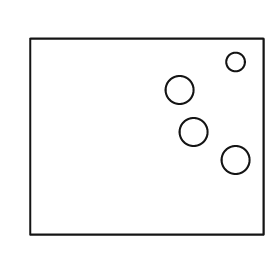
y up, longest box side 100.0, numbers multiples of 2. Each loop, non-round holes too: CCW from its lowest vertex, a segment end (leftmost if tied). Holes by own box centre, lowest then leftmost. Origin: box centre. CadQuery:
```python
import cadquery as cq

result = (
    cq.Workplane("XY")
    .moveTo(-50.0, -42.0)
    .lineTo(50.0, -42.0)
    .lineTo(50.0, 42.0)
    .lineTo(-50.0, 42.0)
    .close()
    .moveTo(38.0, -10.0)
    .circle(6.0)
    .moveTo(20.0, 2.0)
    .circle(6.0)
    .moveTo(14.0, 20.0)
    .circle(6.0)
    .moveTo(38.0, 32.0)
    .circle(4.0)
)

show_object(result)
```